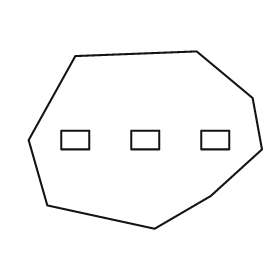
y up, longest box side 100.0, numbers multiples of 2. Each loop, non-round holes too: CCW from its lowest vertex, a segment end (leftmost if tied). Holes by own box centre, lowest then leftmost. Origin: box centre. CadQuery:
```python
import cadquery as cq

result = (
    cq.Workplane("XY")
    .moveTo(4.0, -38.0)
    .lineTo(28.0, -24.0)
    .lineTo(50.0, -4.0)
    .lineTo(46.0, 18.0)
    .lineTo(22.0, 38.0)
    .lineTo(-30.0, 36.0)
    .lineTo(-50.0, 0.0)
    .lineTo(-42.0, -28.0)
    .close()
    .moveTo(-36.0, -4.0)
    .lineTo(-24.0, -4.0)
    .lineTo(-24.0, 4.0)
    .lineTo(-36.0, 4.0)
    .close()
    .moveTo(-6.0, -4.0)
    .lineTo(6.0, -4.0)
    .lineTo(6.0, 4.0)
    .lineTo(-6.0, 4.0)
    .close()
    .moveTo(24.0, -4.0)
    .lineTo(36.0, -4.0)
    .lineTo(36.0, 4.0)
    .lineTo(24.0, 4.0)
    .close()
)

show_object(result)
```